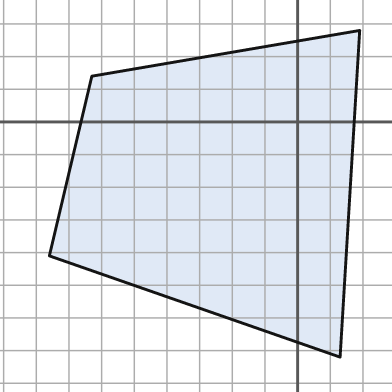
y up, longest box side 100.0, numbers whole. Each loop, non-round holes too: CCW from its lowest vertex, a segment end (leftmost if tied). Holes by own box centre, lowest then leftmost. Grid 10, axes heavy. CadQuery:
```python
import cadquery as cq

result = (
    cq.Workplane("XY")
    .moveTo(13.0, -72.0)
    .lineTo(19.0, 28.0)
    .lineTo(-63.0, 14.0)
    .lineTo(-76.0, -41.0)
    .close()
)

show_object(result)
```